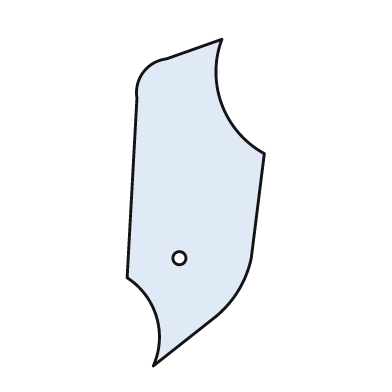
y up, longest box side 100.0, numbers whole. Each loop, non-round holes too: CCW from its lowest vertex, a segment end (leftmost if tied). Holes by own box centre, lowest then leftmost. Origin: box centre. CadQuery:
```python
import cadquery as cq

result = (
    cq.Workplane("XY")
    .moveTo(-13.0, -50.0)
    .lineTo(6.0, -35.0)
    .threePointArc((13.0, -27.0), (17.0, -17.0))
    .lineTo(21.0, 15.0)
    .threePointArc((8.0, 30.0), (8.0, 50.0))
    .lineTo(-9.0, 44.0)
    .threePointArc((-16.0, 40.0), (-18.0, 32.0))
    .lineTo(-21.0, -23.0)
    .threePointArc((-12.0, -35.0), (-13.0, -50.0))
    .close()
    .moveTo(-5.0, -17.0)
    .circle(2.0)
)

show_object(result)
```